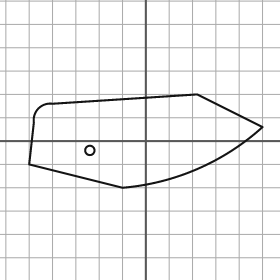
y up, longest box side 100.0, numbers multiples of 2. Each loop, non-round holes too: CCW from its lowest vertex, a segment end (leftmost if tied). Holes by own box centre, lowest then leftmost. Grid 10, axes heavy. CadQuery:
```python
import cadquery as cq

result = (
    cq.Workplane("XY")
    .moveTo(-10.0, -20.0)
    .threePointArc((22.0, -12.0), (50.0, 6.0))
    .lineTo(22.0, 20.0)
    .lineTo(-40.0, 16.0)
    .threePointArc((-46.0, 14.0), (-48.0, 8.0))
    .lineTo(-50.0, -10.0)
    .close()
    .moveTo(-24.0, -4.0)
    .circle(2.0)
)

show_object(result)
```